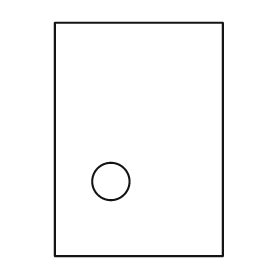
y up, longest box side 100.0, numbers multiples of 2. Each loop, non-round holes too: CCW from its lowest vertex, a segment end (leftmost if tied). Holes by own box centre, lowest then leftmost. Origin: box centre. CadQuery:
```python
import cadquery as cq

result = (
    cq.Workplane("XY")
    .moveTo(-36.0, -50.0)
    .lineTo(36.0, -50.0)
    .lineTo(36.0, 50.0)
    .lineTo(-36.0, 50.0)
    .close()
    .moveTo(-12.0, -18.0)
    .circle(8.0)
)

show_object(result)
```